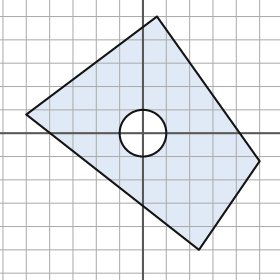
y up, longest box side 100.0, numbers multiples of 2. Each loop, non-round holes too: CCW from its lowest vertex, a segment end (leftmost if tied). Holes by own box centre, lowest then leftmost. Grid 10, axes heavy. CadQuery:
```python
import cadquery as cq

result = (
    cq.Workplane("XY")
    .moveTo(24.0, -50.0)
    .lineTo(50.0, -12.0)
    .lineTo(6.0, 50.0)
    .lineTo(-50.0, 8.0)
    .close()
    .moveTo(0.0, 0.0)
    .circle(10.0)
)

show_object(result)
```